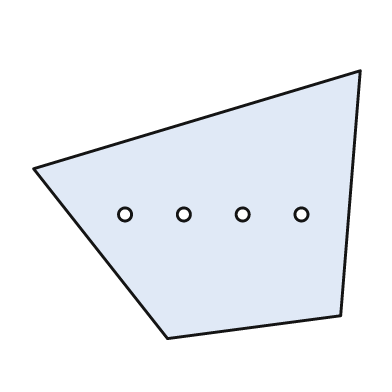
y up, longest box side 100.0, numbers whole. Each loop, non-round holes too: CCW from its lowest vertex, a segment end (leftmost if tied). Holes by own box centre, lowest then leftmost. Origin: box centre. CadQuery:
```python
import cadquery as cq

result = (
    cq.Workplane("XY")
    .moveTo(-9.0, -41.0)
    .lineTo(44.0, -34.0)
    .lineTo(50.0, 41.0)
    .lineTo(-50.0, 11.0)
    .close()
    .moveTo(-22.0, -3.0)
    .circle(2.0)
    .moveTo(-4.0, -3.0)
    .circle(2.0)
    .moveTo(14.0, -3.0)
    .circle(2.0)
    .moveTo(32.0, -3.0)
    .circle(2.0)
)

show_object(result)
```